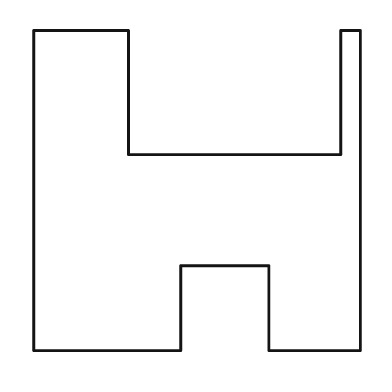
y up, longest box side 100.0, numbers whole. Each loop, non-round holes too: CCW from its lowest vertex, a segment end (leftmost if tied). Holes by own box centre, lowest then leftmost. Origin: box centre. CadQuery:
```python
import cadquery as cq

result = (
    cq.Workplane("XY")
    .moveTo(-50.0, -49.0)
    .lineTo(-5.0, -49.0)
    .lineTo(-5.0, -23.0)
    .lineTo(22.0, -23.0)
    .lineTo(22.0, -49.0)
    .lineTo(50.0, -49.0)
    .lineTo(50.0, 49.0)
    .lineTo(44.0, 49.0)
    .lineTo(44.0, 11.0)
    .lineTo(-21.0, 11.0)
    .lineTo(-21.0, 49.0)
    .lineTo(-50.0, 49.0)
    .close()
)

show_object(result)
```